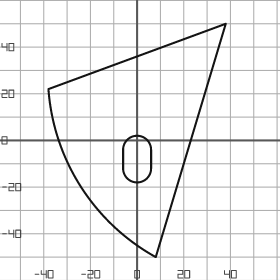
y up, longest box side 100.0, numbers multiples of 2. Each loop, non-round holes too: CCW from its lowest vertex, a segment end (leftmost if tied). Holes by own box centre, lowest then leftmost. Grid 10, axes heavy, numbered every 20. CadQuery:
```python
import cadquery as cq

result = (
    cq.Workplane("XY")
    .moveTo(8.0, -50.0)
    .lineTo(38.0, 50.0)
    .lineTo(-38.0, 22.0)
    .threePointArc((-24.0, -20.0), (8.0, -50.0))
    .close()
    .moveTo(-6.0, -12.0)
    .threePointArc((0.0, -18.0), (6.0, -12.0))
    .lineTo(6.0, -4.0)
    .threePointArc((0.0, 2.0), (-6.0, -4.0))
    .close()
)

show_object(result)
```